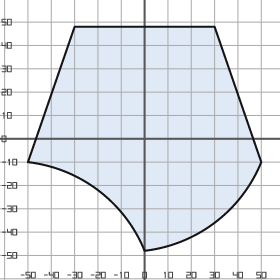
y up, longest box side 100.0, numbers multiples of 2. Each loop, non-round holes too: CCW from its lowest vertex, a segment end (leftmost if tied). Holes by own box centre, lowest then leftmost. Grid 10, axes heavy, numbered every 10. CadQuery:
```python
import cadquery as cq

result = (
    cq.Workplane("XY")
    .moveTo(0.0, -48.0)
    .threePointArc((30.0, -36.0), (50.0, -10.0))
    .lineTo(30.0, 48.0)
    .lineTo(-30.0, 48.0)
    .lineTo(-50.0, -10.0)
    .threePointArc((-20.0, -22.0), (0.0, -48.0))
    .close()
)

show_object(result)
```